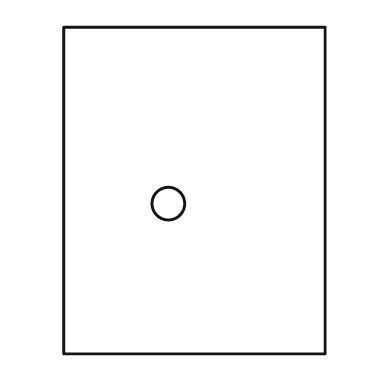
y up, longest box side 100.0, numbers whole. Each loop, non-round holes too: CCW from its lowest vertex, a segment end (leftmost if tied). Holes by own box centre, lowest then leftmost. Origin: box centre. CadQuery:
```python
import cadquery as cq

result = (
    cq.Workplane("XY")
    .moveTo(-40.0, -50.0)
    .lineTo(40.0, -50.0)
    .lineTo(40.0, 50.0)
    .lineTo(-40.0, 50.0)
    .close()
    .moveTo(-8.0, -4.0)
    .circle(5.0)
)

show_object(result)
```